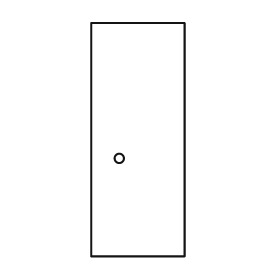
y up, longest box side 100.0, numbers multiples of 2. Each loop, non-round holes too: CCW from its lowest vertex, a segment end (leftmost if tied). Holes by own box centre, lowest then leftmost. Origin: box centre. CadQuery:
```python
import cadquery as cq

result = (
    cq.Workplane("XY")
    .moveTo(-20.0, -50.0)
    .lineTo(20.0, -50.0)
    .lineTo(20.0, 50.0)
    .lineTo(-20.0, 50.0)
    .close()
    .moveTo(-8.0, -8.0)
    .circle(2.0)
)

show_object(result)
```